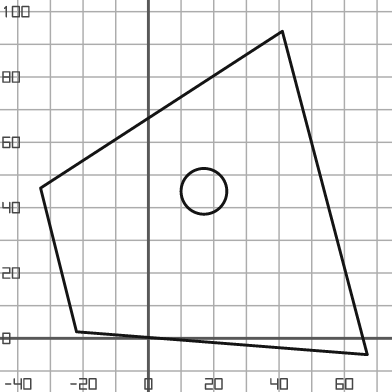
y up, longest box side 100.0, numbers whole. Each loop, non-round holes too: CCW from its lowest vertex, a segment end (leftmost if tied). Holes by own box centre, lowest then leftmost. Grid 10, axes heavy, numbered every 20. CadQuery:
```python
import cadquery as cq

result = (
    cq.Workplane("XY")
    .moveTo(67.0, -5.0)
    .lineTo(41.0, 94.0)
    .lineTo(-33.0, 46.0)
    .lineTo(-22.0, 2.0)
    .close()
    .moveTo(17.0, 45.0)
    .circle(7.0)
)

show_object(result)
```